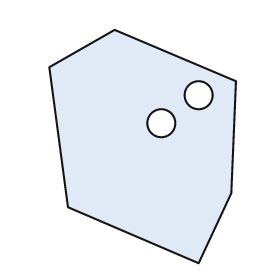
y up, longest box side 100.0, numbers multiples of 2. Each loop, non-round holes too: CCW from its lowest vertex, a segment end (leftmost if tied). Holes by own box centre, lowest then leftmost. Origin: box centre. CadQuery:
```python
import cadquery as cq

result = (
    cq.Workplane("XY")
    .moveTo(24.0, -50.0)
    .lineTo(38.0, -20.0)
    .lineTo(40.0, 28.0)
    .lineTo(-12.0, 50.0)
    .lineTo(-40.0, 34.0)
    .lineTo(-32.0, -26.0)
    .close()
    .moveTo(8.0, 10.0)
    .circle(6.0)
    .moveTo(24.0, 22.0)
    .circle(6.0)
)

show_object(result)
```